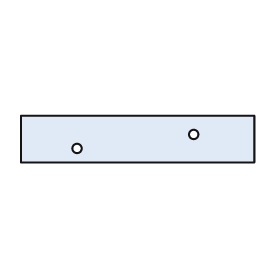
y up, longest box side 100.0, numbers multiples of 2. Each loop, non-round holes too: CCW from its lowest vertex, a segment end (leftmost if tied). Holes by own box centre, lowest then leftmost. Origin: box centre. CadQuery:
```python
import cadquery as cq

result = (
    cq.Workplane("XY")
    .moveTo(-50.0, -10.0)
    .lineTo(50.0, -10.0)
    .lineTo(50.0, 10.0)
    .lineTo(-50.0, 10.0)
    .close()
    .moveTo(-26.0, -4.0)
    .circle(2.0)
    .moveTo(24.0, 2.0)
    .circle(2.0)
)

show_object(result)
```